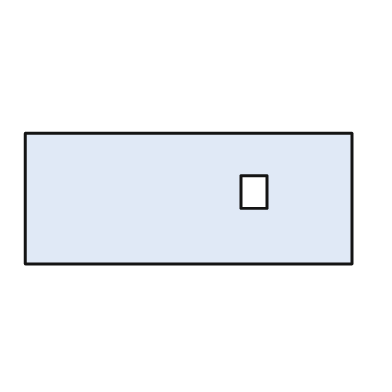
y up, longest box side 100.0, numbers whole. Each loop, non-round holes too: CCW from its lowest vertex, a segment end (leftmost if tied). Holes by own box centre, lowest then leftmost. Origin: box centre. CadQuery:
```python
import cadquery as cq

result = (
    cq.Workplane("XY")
    .moveTo(-50.0, -20.0)
    .lineTo(50.0, -20.0)
    .lineTo(50.0, 20.0)
    .lineTo(-50.0, 20.0)
    .close()
    .moveTo(16.0, -3.0)
    .lineTo(24.0, -3.0)
    .lineTo(24.0, 7.0)
    .lineTo(16.0, 7.0)
    .close()
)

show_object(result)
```